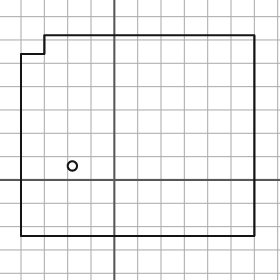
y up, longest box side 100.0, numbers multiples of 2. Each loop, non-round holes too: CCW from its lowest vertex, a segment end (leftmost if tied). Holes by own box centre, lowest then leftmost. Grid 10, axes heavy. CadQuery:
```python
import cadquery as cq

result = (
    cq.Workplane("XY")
    .moveTo(-40.0, -24.0)
    .lineTo(60.0, -24.0)
    .lineTo(60.0, 62.0)
    .lineTo(-30.0, 62.0)
    .lineTo(-30.0, 54.0)
    .lineTo(-40.0, 54.0)
    .close()
    .moveTo(-18.0, 6.0)
    .circle(2.0)
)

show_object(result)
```